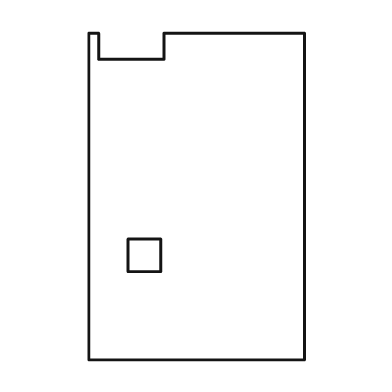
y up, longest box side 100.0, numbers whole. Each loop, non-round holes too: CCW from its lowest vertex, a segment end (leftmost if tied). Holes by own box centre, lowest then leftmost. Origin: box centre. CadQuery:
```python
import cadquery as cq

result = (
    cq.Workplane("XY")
    .moveTo(-33.0, -50.0)
    .lineTo(33.0, -50.0)
    .lineTo(33.0, 50.0)
    .lineTo(-10.0, 50.0)
    .lineTo(-10.0, 42.0)
    .lineTo(-30.0, 42.0)
    .lineTo(-30.0, 50.0)
    .lineTo(-33.0, 50.0)
    .close()
    .moveTo(-21.0, -23.0)
    .lineTo(-11.0, -23.0)
    .lineTo(-11.0, -13.0)
    .lineTo(-21.0, -13.0)
    .close()
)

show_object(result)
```